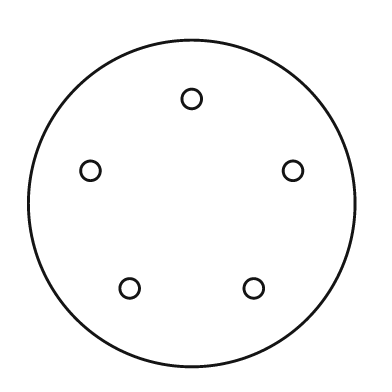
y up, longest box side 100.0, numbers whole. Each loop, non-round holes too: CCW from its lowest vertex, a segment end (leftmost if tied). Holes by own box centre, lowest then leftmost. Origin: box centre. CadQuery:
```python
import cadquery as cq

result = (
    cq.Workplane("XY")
    .moveTo(0.0, 0.0)
    .circle(50.0)
    .moveTo(-19.0, -26.0)
    .circle(3.0)
    .moveTo(19.0, -26.0)
    .circle(3.0)
    .moveTo(-31.0, 10.0)
    .circle(3.0)
    .moveTo(31.0, 10.0)
    .circle(3.0)
    .moveTo(0.0, 32.0)
    .circle(3.0)
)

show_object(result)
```